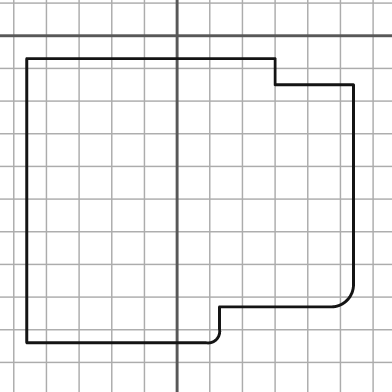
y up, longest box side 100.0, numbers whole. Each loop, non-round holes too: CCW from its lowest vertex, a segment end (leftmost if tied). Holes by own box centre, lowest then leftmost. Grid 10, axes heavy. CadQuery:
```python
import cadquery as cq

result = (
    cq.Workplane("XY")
    .moveTo(-46.0, -94.0)
    .lineTo(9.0, -94.0)
    .threePointArc((12.0, -93.0), (13.0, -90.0))
    .lineTo(13.0, -83.0)
    .lineTo(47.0, -83.0)
    .threePointArc((52.0, -81.0), (54.0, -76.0))
    .lineTo(54.0, -15.0)
    .lineTo(30.0, -15.0)
    .lineTo(30.0, -7.0)
    .lineTo(-46.0, -7.0)
    .close()
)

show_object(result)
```